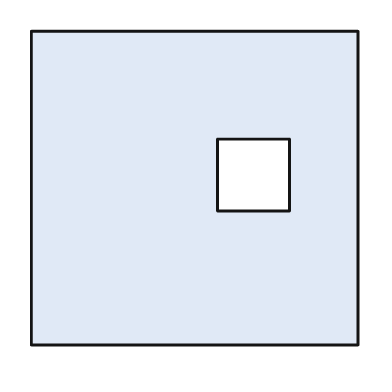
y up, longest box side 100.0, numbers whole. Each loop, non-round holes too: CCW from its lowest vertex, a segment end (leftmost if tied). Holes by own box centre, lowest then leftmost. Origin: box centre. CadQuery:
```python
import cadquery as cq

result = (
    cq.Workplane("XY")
    .moveTo(-50.0, -48.0)
    .lineTo(50.0, -48.0)
    .lineTo(50.0, 48.0)
    .lineTo(-50.0, 48.0)
    .close()
    .moveTo(7.0, -7.0)
    .lineTo(29.0, -7.0)
    .lineTo(29.0, 15.0)
    .lineTo(7.0, 15.0)
    .close()
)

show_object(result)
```